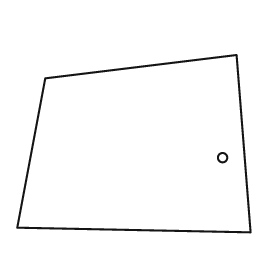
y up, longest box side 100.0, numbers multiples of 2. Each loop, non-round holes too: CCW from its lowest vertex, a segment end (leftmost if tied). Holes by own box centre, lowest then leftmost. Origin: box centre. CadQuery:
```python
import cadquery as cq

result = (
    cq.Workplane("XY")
    .moveTo(50.0, -38.0)
    .lineTo(44.0, 38.0)
    .lineTo(-38.0, 28.0)
    .lineTo(-50.0, -36.0)
    .close()
    .moveTo(38.0, -6.0)
    .circle(2.0)
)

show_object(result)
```